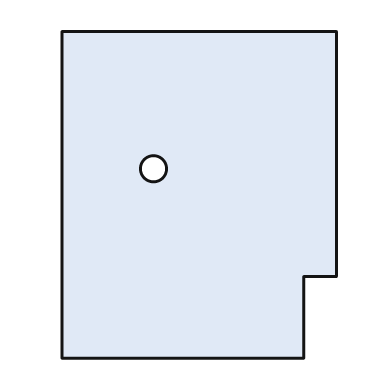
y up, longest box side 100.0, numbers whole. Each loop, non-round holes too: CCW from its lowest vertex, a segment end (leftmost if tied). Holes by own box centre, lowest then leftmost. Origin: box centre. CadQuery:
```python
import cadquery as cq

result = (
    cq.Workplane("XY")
    .moveTo(-42.0, -50.0)
    .lineTo(32.0, -50.0)
    .lineTo(32.0, -25.0)
    .lineTo(42.0, -25.0)
    .lineTo(42.0, 50.0)
    .lineTo(-42.0, 50.0)
    .close()
    .moveTo(-14.0, 8.0)
    .circle(4.0)
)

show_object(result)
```